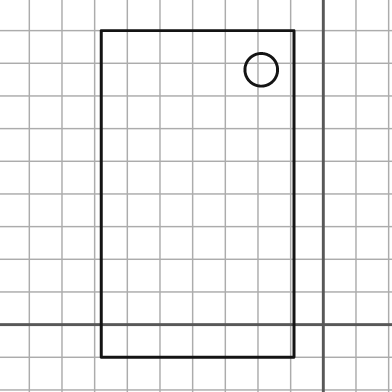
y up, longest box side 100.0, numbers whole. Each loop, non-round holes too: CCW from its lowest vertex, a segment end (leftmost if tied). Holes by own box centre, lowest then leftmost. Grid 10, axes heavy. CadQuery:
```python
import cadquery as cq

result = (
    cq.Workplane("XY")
    .moveTo(-68.0, -10.0)
    .lineTo(-9.0, -10.0)
    .lineTo(-9.0, 90.0)
    .lineTo(-68.0, 90.0)
    .close()
    .moveTo(-19.0, 78.0)
    .circle(5.0)
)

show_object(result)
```